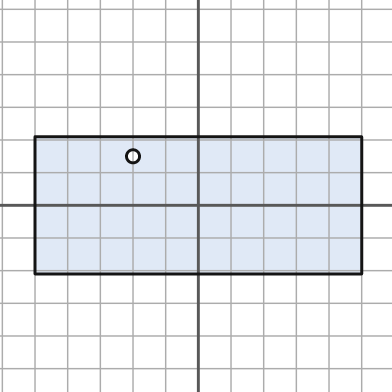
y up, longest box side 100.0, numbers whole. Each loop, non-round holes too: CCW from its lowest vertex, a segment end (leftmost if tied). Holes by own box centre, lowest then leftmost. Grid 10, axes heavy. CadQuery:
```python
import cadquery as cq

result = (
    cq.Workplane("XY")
    .moveTo(-50.0, -21.0)
    .lineTo(50.0, -21.0)
    .lineTo(50.0, 21.0)
    .lineTo(-50.0, 21.0)
    .close()
    .moveTo(-20.0, 15.0)
    .circle(2.0)
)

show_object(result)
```